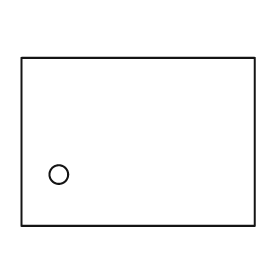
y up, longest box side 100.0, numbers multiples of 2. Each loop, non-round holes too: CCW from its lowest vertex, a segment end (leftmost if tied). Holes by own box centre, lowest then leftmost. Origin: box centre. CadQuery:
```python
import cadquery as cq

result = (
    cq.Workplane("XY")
    .moveTo(-50.0, -36.0)
    .lineTo(50.0, -36.0)
    .lineTo(50.0, 36.0)
    .lineTo(-50.0, 36.0)
    .close()
    .moveTo(-34.0, -14.0)
    .circle(4.0)
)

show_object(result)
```